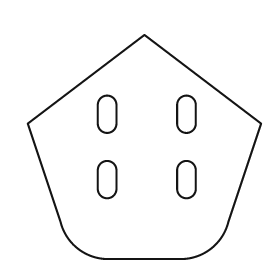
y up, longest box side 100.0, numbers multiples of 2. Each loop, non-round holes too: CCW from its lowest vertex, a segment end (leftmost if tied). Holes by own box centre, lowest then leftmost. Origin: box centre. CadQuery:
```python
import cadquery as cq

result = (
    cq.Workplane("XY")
    .moveTo(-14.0, -48.0)
    .lineTo(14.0, -48.0)
    .threePointArc((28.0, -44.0), (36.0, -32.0))
    .lineTo(50.0, 10.0)
    .lineTo(0.0, 48.0)
    .lineTo(-50.0, 10.0)
    .lineTo(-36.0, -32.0)
    .threePointArc((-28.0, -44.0), (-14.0, -48.0))
    .close()
    .moveTo(-20.0, -18.0)
    .threePointArc((-16.0, -22.0), (-12.0, -18.0))
    .lineTo(-12.0, -10.0)
    .threePointArc((-16.0, -6.0), (-20.0, -10.0))
    .close()
    .moveTo(14.0, -18.0)
    .threePointArc((18.0, -22.0), (22.0, -18.0))
    .lineTo(22.0, -10.0)
    .threePointArc((18.0, -6.0), (14.0, -10.0))
    .close()
    .moveTo(-20.0, 10.0)
    .threePointArc((-16.0, 6.0), (-12.0, 10.0))
    .lineTo(-12.0, 18.0)
    .threePointArc((-16.0, 22.0), (-20.0, 18.0))
    .close()
    .moveTo(14.0, 10.0)
    .threePointArc((18.0, 6.0), (22.0, 10.0))
    .lineTo(22.0, 18.0)
    .threePointArc((18.0, 22.0), (14.0, 18.0))
    .close()
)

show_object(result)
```